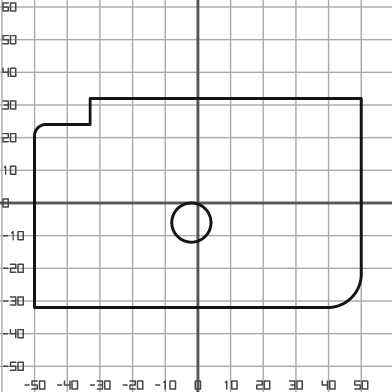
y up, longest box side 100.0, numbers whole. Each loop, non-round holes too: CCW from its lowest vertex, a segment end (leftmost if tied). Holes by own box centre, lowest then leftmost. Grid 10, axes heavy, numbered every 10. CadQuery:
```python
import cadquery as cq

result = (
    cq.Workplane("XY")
    .moveTo(-50.0, -32.0)
    .lineTo(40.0, -32.0)
    .threePointArc((47.0, -29.0), (50.0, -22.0))
    .lineTo(50.0, 32.0)
    .lineTo(-33.0, 32.0)
    .lineTo(-33.0, 24.0)
    .lineTo(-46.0, 24.0)
    .threePointArc((-49.0, 23.0), (-50.0, 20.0))
    .close()
    .moveTo(-2.0, -6.0)
    .circle(6.0)
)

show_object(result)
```